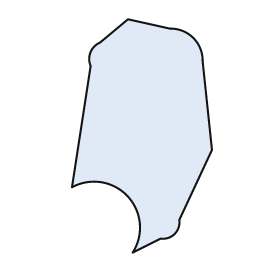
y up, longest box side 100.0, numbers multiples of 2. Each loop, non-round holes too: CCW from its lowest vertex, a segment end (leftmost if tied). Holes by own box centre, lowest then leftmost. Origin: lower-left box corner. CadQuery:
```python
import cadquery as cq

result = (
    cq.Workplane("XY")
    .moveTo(26.0, 0.0)
    .lineTo(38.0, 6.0)
    .threePointArc((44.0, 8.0), (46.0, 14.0))
    .lineTo(60.0, 44.0)
    .lineTo(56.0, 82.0)
    .threePointArc((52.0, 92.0), (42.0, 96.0))
    .lineTo(24.0, 100.0)
    .lineTo(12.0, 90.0)
    .threePointArc((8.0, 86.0), (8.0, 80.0))
    .lineTo(0.0, 28.0)
    .threePointArc((24.0, 24.0), (26.0, 0.0))
    .close()
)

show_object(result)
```